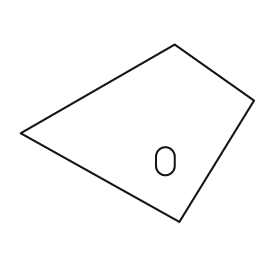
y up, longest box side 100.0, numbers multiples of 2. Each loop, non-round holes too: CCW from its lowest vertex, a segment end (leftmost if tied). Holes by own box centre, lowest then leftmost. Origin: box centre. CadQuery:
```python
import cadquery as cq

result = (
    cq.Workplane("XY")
    .moveTo(18.0, -38.0)
    .lineTo(50.0, 14.0)
    .lineTo(16.0, 38.0)
    .lineTo(-50.0, 0.0)
    .close()
    .moveTo(8.0, -14.0)
    .threePointArc((12.0, -18.0), (16.0, -14.0))
    .lineTo(16.0, -10.0)
    .threePointArc((12.0, -6.0), (8.0, -10.0))
    .close()
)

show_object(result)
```